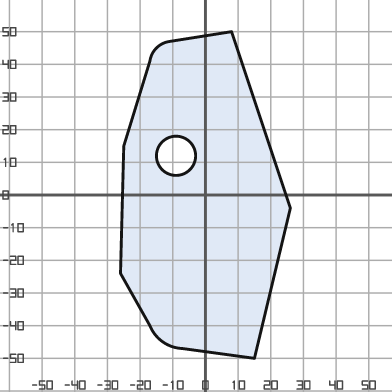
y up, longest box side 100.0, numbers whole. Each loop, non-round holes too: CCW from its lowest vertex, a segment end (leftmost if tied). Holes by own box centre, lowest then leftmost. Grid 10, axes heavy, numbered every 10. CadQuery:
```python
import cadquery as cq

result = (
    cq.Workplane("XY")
    .moveTo(15.0, -50.0)
    .lineTo(26.0, -4.0)
    .lineTo(8.0, 50.0)
    .lineTo(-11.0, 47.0)
    .threePointArc((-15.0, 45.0), (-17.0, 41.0))
    .lineTo(-25.0, 15.0)
    .lineTo(-26.0, -24.0)
    .lineTo(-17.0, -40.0)
    .threePointArc((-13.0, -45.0), (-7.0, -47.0))
    .close()
    .moveTo(-9.0, 12.0)
    .circle(6.0)
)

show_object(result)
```